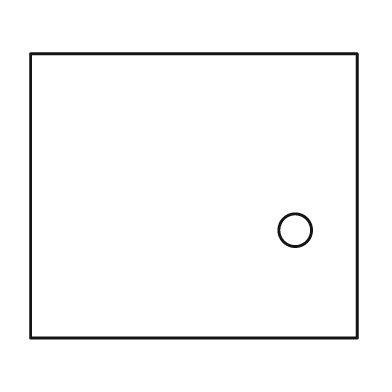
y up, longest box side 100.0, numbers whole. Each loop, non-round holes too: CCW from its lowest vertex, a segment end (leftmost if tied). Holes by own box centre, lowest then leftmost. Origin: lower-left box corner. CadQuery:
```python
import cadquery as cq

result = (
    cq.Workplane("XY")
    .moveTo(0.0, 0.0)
    .lineTo(100.0, 0.0)
    .lineTo(100.0, 87.0)
    .lineTo(0.0, 87.0)
    .close()
    .moveTo(81.0, 33.0)
    .circle(5.0)
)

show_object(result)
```